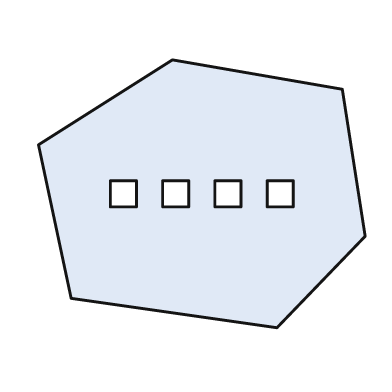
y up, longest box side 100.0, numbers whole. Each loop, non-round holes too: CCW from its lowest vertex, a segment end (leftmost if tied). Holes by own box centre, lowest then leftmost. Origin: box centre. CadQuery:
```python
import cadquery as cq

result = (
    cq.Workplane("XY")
    .moveTo(23.0, -41.0)
    .lineTo(50.0, -13.0)
    .lineTo(43.0, 32.0)
    .lineTo(-9.0, 41.0)
    .lineTo(-50.0, 15.0)
    .lineTo(-40.0, -32.0)
    .close()
    .moveTo(-28.0, -4.0)
    .lineTo(-20.0, -4.0)
    .lineTo(-20.0, 4.0)
    .lineTo(-28.0, 4.0)
    .close()
    .moveTo(-12.0, -4.0)
    .lineTo(-4.0, -4.0)
    .lineTo(-4.0, 4.0)
    .lineTo(-12.0, 4.0)
    .close()
    .moveTo(4.0, -4.0)
    .lineTo(12.0, -4.0)
    .lineTo(12.0, 4.0)
    .lineTo(4.0, 4.0)
    .close()
    .moveTo(20.0, -4.0)
    .lineTo(28.0, -4.0)
    .lineTo(28.0, 4.0)
    .lineTo(20.0, 4.0)
    .close()
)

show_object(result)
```